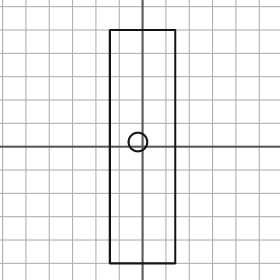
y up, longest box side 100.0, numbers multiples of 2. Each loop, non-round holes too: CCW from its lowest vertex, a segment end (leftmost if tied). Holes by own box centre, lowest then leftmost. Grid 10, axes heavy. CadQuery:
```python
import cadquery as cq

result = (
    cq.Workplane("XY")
    .moveTo(-14.0, -50.0)
    .lineTo(14.0, -50.0)
    .lineTo(14.0, 50.0)
    .lineTo(-14.0, 50.0)
    .close()
    .moveTo(-2.0, 2.0)
    .circle(4.0)
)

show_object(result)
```